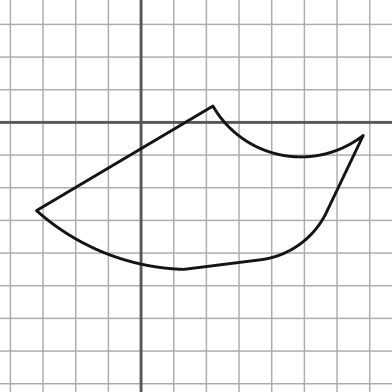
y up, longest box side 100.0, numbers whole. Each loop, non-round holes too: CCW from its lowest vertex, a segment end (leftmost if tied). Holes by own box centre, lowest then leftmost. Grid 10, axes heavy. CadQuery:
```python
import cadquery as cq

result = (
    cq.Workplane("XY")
    .moveTo(13.0, -45.0)
    .lineTo(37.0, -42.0)
    .threePointArc((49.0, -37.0), (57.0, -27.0))
    .lineTo(68.0, -4.0)
    .threePointArc((43.0, -10.0), (22.0, 5.0))
    .lineTo(-32.0, -27.0)
    .threePointArc((-11.0, -40.0), (13.0, -45.0))
    .close()
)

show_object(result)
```